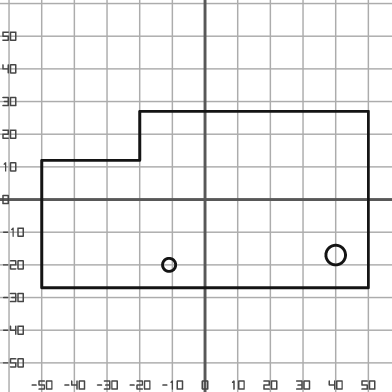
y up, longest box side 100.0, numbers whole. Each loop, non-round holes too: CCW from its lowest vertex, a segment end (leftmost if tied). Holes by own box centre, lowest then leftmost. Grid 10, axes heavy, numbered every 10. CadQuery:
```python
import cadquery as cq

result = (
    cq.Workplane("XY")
    .moveTo(-50.0, -27.0)
    .lineTo(50.0, -27.0)
    .lineTo(50.0, 27.0)
    .lineTo(-20.0, 27.0)
    .lineTo(-20.0, 12.0)
    .lineTo(-50.0, 12.0)
    .close()
    .moveTo(-11.0, -20.0)
    .circle(2.0)
    .moveTo(40.0, -17.0)
    .circle(3.0)
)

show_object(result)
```